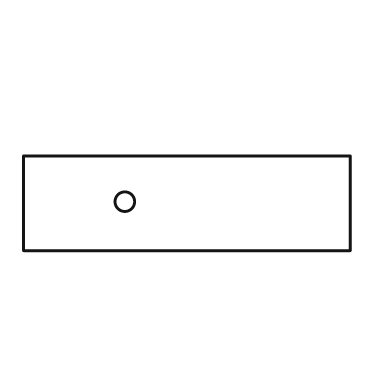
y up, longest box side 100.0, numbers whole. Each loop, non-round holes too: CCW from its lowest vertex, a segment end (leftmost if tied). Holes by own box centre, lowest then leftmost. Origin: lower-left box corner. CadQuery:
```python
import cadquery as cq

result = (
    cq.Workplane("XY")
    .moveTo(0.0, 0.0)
    .lineTo(100.0, 0.0)
    .lineTo(100.0, 29.0)
    .lineTo(0.0, 29.0)
    .close()
    .moveTo(31.0, 15.0)
    .circle(3.0)
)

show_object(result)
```